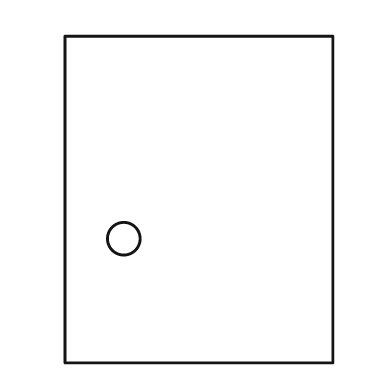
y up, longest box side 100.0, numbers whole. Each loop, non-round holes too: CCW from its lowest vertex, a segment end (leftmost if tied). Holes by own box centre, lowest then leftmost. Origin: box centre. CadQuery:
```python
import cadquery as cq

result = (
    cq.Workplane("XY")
    .moveTo(-41.0, -50.0)
    .lineTo(41.0, -50.0)
    .lineTo(41.0, 50.0)
    .lineTo(-41.0, 50.0)
    .close()
    .moveTo(-23.0, -12.0)
    .circle(5.0)
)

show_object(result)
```